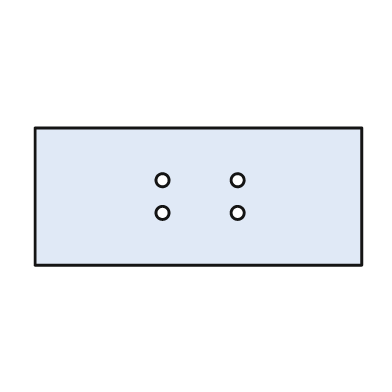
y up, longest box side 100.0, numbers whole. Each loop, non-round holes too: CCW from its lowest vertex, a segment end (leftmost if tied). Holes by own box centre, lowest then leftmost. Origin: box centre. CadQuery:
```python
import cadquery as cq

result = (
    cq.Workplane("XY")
    .moveTo(-50.0, -21.0)
    .lineTo(50.0, -21.0)
    .lineTo(50.0, 21.0)
    .lineTo(-50.0, 21.0)
    .close()
    .moveTo(-11.0, -5.0)
    .circle(2.0)
    .moveTo(12.0, -5.0)
    .circle(2.0)
    .moveTo(-11.0, 5.0)
    .circle(2.0)
    .moveTo(12.0, 5.0)
    .circle(2.0)
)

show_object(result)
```